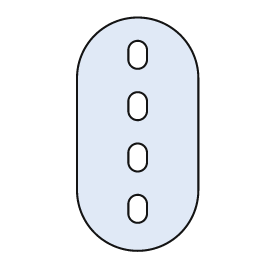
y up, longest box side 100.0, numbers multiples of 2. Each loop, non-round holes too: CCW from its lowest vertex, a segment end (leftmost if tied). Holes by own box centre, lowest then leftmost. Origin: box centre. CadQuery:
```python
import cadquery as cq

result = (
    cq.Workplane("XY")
    .moveTo(-26.0, -24.0)
    .threePointArc((0.0, -50.0), (26.0, -24.0))
    .lineTo(26.0, 24.0)
    .threePointArc((0.0, 50.0), (-26.0, 24.0))
    .close()
    .moveTo(-4.0, -34.0)
    .threePointArc((0.0, -38.0), (4.0, -34.0))
    .lineTo(4.0, -30.0)
    .threePointArc((0.0, -26.0), (-4.0, -30.0))
    .close()
    .moveTo(-4.0, -12.0)
    .threePointArc((0.0, -16.0), (4.0, -12.0))
    .lineTo(4.0, -8.0)
    .threePointArc((0.0, -4.0), (-4.0, -8.0))
    .close()
    .moveTo(-4.0, 10.0)
    .threePointArc((0.0, 6.0), (4.0, 10.0))
    .lineTo(4.0, 14.0)
    .threePointArc((0.0, 18.0), (-4.0, 14.0))
    .close()
    .moveTo(-4.0, 32.0)
    .threePointArc((0.0, 28.0), (4.0, 32.0))
    .lineTo(4.0, 36.0)
    .threePointArc((0.0, 40.0), (-4.0, 36.0))
    .close()
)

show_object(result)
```